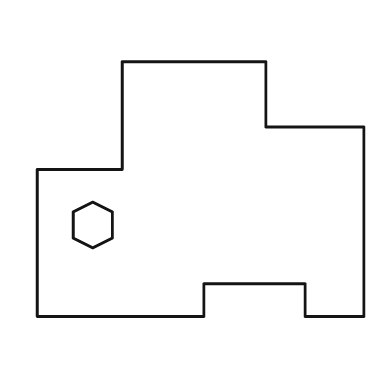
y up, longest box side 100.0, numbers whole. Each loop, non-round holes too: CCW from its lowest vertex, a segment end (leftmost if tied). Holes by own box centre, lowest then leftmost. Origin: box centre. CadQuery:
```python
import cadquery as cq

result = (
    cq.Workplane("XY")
    .moveTo(-50.0, -39.0)
    .lineTo(1.0, -39.0)
    .lineTo(1.0, -29.0)
    .lineTo(32.0, -29.0)
    .lineTo(32.0, -39.0)
    .lineTo(50.0, -39.0)
    .lineTo(50.0, 19.0)
    .lineTo(20.0, 19.0)
    .lineTo(20.0, 39.0)
    .lineTo(-24.0, 39.0)
    .lineTo(-24.0, 6.0)
    .lineTo(-50.0, 6.0)
    .close()
    .moveTo(-33.0, -18.0)
    .lineTo(-27.0, -15.0)
    .lineTo(-27.0, -7.0)
    .lineTo(-33.0, -4.0)
    .lineTo(-39.0, -7.0)
    .lineTo(-39.0, -15.0)
    .close()
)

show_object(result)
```